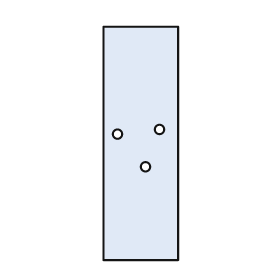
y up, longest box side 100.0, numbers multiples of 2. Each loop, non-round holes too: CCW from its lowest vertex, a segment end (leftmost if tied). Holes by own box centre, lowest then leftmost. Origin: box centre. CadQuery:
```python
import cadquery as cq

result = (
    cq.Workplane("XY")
    .moveTo(-16.0, -50.0)
    .lineTo(16.0, -50.0)
    .lineTo(16.0, 50.0)
    .lineTo(-16.0, 50.0)
    .close()
    .moveTo(2.0, -10.0)
    .circle(2.0)
    .moveTo(-10.0, 4.0)
    .circle(2.0)
    .moveTo(8.0, 6.0)
    .circle(2.0)
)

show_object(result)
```